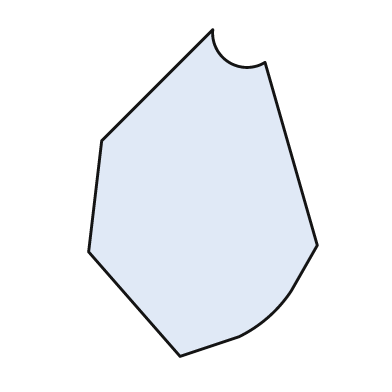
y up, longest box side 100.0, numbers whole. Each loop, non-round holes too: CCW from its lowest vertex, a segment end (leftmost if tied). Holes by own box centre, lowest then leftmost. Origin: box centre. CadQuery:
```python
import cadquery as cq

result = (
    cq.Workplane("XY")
    .moveTo(-7.0, -50.0)
    .lineTo(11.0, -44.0)
    .threePointArc((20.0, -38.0), (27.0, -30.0))
    .lineTo(35.0, -16.0)
    .lineTo(19.0, 40.0)
    .threePointArc((8.0, 40.0), (3.0, 50.0))
    .lineTo(-31.0, 16.0)
    .lineTo(-35.0, -18.0)
    .close()
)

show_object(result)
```